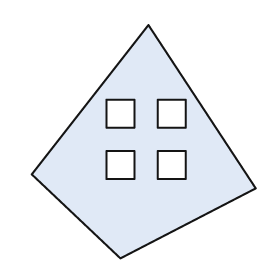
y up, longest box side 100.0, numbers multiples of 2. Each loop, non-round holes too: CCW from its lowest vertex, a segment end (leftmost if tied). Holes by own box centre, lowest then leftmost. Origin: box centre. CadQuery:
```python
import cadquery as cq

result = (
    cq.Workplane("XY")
    .moveTo(-10.0, -50.0)
    .lineTo(48.0, -20.0)
    .lineTo(2.0, 50.0)
    .lineTo(-48.0, -14.0)
    .close()
    .moveTo(-16.0, -16.0)
    .lineTo(-4.0, -16.0)
    .lineTo(-4.0, -4.0)
    .lineTo(-16.0, -4.0)
    .close()
    .moveTo(6.0, -16.0)
    .lineTo(18.0, -16.0)
    .lineTo(18.0, -4.0)
    .lineTo(6.0, -4.0)
    .close()
    .moveTo(-16.0, 6.0)
    .lineTo(-4.0, 6.0)
    .lineTo(-4.0, 18.0)
    .lineTo(-16.0, 18.0)
    .close()
    .moveTo(6.0, 6.0)
    .lineTo(18.0, 6.0)
    .lineTo(18.0, 18.0)
    .lineTo(6.0, 18.0)
    .close()
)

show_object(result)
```